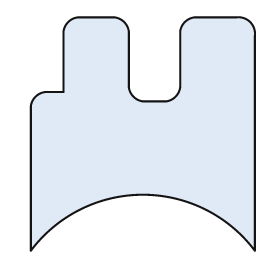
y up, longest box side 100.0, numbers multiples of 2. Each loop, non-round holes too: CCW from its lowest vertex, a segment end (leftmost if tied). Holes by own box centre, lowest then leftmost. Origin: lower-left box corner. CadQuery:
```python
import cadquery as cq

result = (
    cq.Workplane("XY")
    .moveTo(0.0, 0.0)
    .threePointArc((48.0, 24.0), (96.0, 0.0))
    .lineTo(96.0, 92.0)
    .threePointArc((94.0, 98.0), (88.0, 100.0))
    .lineTo(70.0, 100.0)
    .threePointArc((66.0, 98.0), (64.0, 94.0))
    .lineTo(64.0, 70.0)
    .threePointArc((62.0, 66.0), (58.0, 64.0))
    .lineTo(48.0, 64.0)
    .threePointArc((44.0, 66.0), (42.0, 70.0))
    .lineTo(42.0, 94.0)
    .threePointArc((40.0, 98.0), (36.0, 100.0))
    .lineTo(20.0, 100.0)
    .threePointArc((16.0, 98.0), (14.0, 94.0))
    .lineTo(14.0, 68.0)
    .lineTo(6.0, 68.0)
    .threePointArc((2.0, 66.0), (0.0, 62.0))
    .close()
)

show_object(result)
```